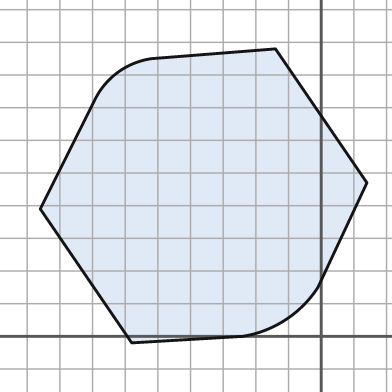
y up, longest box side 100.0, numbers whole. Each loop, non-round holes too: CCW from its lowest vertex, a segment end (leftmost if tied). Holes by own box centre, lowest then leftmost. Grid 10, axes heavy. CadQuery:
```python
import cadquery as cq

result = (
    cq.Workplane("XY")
    .moveTo(-58.0, -2.0)
    .lineTo(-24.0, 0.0)
    .threePointArc((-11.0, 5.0), (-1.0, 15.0))
    .lineTo(14.0, 47.0)
    .lineTo(-14.0, 88.0)
    .lineTo(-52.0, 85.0)
    .threePointArc((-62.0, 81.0), (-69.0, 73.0))
    .lineTo(-86.0, 39.0)
    .close()
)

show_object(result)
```